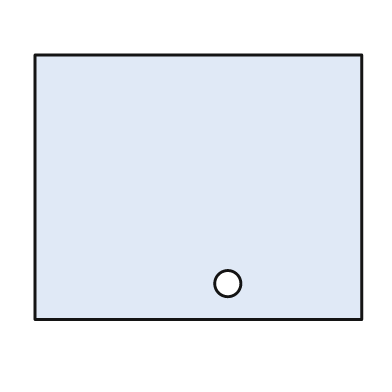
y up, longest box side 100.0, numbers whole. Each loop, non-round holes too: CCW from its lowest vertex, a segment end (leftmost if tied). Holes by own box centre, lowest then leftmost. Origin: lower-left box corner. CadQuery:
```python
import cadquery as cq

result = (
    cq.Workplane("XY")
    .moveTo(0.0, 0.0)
    .lineTo(100.0, 0.0)
    .lineTo(100.0, 81.0)
    .lineTo(0.0, 81.0)
    .close()
    .moveTo(59.0, 11.0)
    .circle(4.0)
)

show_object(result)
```